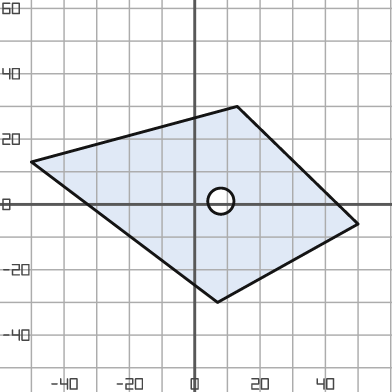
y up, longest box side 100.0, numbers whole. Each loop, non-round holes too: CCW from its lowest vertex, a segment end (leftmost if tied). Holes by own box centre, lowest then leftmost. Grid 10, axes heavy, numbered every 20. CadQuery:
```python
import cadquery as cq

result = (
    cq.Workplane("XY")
    .moveTo(7.0, -30.0)
    .lineTo(50.0, -6.0)
    .lineTo(13.0, 30.0)
    .lineTo(-50.0, 13.0)
    .close()
    .moveTo(8.0, 1.0)
    .circle(4.0)
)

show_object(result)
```